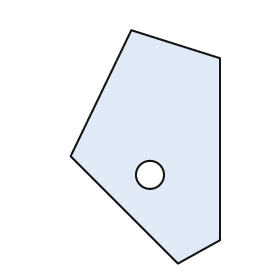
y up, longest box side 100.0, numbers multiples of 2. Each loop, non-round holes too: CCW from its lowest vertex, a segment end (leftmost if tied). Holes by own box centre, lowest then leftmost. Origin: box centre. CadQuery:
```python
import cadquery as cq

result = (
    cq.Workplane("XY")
    .moveTo(14.0, -50.0)
    .lineTo(32.0, -40.0)
    .lineTo(32.0, 38.0)
    .lineTo(-6.0, 50.0)
    .lineTo(-32.0, -4.0)
    .close()
    .moveTo(2.0, -12.0)
    .circle(6.0)
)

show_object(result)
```